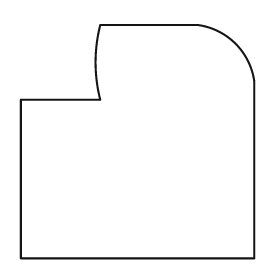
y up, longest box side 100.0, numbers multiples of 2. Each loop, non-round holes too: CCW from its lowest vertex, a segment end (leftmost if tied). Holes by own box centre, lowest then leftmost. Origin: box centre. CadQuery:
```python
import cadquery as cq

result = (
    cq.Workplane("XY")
    .moveTo(-50.0, -50.0)
    .lineTo(50.0, -50.0)
    .lineTo(50.0, 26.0)
    .threePointArc((42.0, 42.0), (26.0, 50.0))
    .lineTo(-16.0, 50.0)
    .threePointArc((-18.0, 34.0), (-16.0, 18.0))
    .lineTo(-50.0, 18.0)
    .close()
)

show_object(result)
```